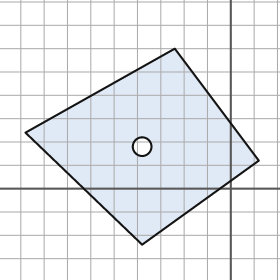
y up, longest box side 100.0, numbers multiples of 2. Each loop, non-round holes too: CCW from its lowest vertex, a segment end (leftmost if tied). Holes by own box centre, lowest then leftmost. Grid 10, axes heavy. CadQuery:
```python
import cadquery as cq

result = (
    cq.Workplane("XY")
    .moveTo(-38.0, -24.0)
    .lineTo(12.0, 12.0)
    .lineTo(-24.0, 60.0)
    .lineTo(-88.0, 24.0)
    .close()
    .moveTo(-38.0, 18.0)
    .circle(4.0)
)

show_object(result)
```